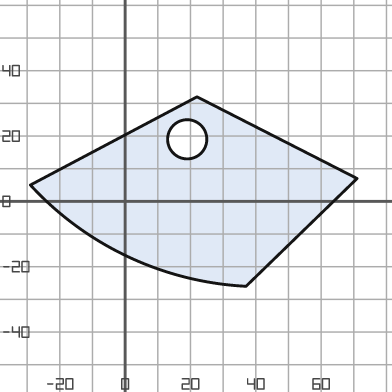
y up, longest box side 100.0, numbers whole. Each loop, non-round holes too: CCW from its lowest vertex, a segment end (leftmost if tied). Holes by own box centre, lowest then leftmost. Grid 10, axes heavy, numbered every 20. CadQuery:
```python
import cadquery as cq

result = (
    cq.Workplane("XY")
    .moveTo(37.0, -26.0)
    .lineTo(71.0, 7.0)
    .lineTo(22.0, 32.0)
    .lineTo(-29.0, 5.0)
    .threePointArc((1.0, -17.0), (37.0, -26.0))
    .close()
    .moveTo(19.0, 19.0)
    .circle(6.0)
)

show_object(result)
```